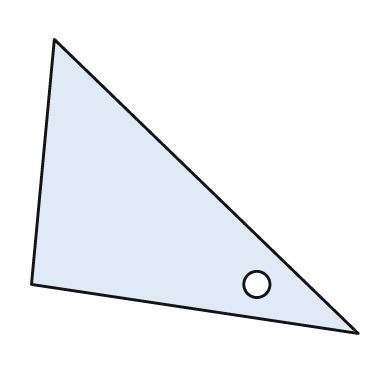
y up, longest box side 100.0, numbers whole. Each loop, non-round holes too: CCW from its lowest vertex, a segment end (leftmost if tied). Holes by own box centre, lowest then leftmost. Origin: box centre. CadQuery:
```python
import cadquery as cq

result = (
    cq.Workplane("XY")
    .moveTo(50.0, -45.0)
    .lineTo(-43.0, 45.0)
    .lineTo(-50.0, -30.0)
    .close()
    .moveTo(19.0, -30.0)
    .circle(4.0)
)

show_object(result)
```